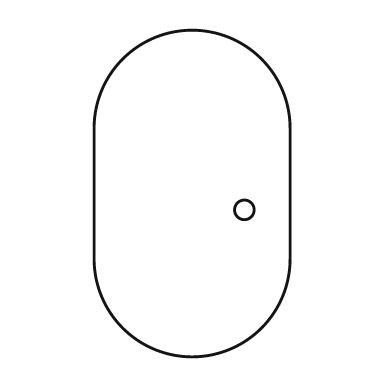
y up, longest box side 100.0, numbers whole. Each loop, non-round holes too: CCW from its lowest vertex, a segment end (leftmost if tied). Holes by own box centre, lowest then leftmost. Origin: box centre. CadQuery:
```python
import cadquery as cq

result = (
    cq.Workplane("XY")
    .moveTo(-30.0, -20.0)
    .threePointArc((0.0, -50.0), (30.0, -20.0))
    .lineTo(30.0, 20.0)
    .threePointArc((0.0, 50.0), (-30.0, 20.0))
    .close()
    .moveTo(16.0, -5.0)
    .circle(3.0)
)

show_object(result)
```